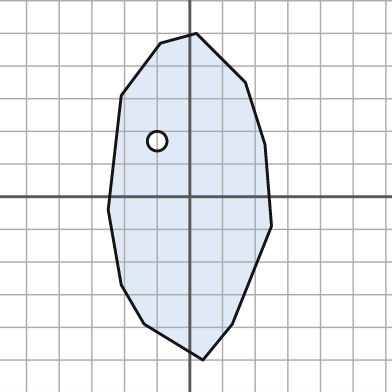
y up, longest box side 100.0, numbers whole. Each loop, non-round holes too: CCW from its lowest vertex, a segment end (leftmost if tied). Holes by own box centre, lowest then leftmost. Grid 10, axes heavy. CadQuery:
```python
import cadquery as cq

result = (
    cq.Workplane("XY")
    .moveTo(4.0, -50.0)
    .lineTo(13.0, -39.0)
    .lineTo(25.0, -9.0)
    .lineTo(23.0, 16.0)
    .lineTo(17.0, 35.0)
    .lineTo(2.0, 50.0)
    .lineTo(-9.0, 47.0)
    .lineTo(-21.0, 31.0)
    .lineTo(-25.0, -4.0)
    .lineTo(-21.0, -27.0)
    .lineTo(-14.0, -39.0)
    .close()
    .moveTo(-10.0, 17.0)
    .circle(3.0)
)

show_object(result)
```